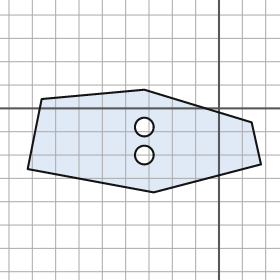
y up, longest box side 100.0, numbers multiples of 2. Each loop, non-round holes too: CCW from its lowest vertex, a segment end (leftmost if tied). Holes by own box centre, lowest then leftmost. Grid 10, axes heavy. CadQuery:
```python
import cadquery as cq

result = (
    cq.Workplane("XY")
    .moveTo(-28.0, -36.0)
    .lineTo(18.0, -24.0)
    .lineTo(14.0, -6.0)
    .lineTo(-32.0, 8.0)
    .lineTo(-76.0, 4.0)
    .lineTo(-82.0, -26.0)
    .close()
    .moveTo(-32.0, -20.0)
    .circle(4.0)
    .moveTo(-32.0, -8.0)
    .circle(4.0)
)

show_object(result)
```